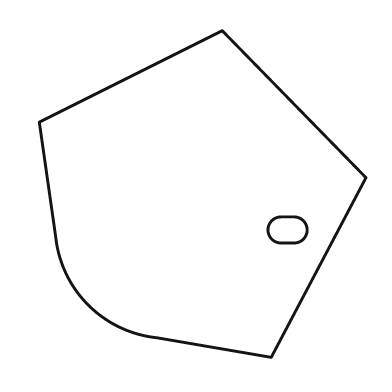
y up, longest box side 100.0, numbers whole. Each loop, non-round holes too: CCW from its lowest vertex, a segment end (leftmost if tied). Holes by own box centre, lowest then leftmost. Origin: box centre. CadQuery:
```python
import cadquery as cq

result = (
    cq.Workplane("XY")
    .moveTo(21.0, -50.0)
    .lineTo(50.0, 5.0)
    .lineTo(6.0, 50.0)
    .lineTo(-50.0, 22.0)
    .lineTo(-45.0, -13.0)
    .threePointArc((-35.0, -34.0), (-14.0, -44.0))
    .close()
    .moveTo(24.0, -15.0)
    .lineTo(28.0, -15.0)
    .threePointArc((32.0, -11.0), (28.0, -7.0))
    .lineTo(24.0, -7.0)
    .threePointArc((20.0, -11.0), (24.0, -15.0))
    .close()
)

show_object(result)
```